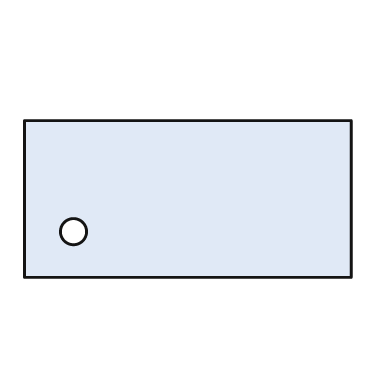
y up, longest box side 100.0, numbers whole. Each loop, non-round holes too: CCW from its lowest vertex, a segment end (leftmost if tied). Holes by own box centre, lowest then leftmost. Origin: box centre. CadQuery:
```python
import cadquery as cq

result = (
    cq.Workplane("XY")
    .moveTo(-50.0, -24.0)
    .lineTo(50.0, -24.0)
    .lineTo(50.0, 24.0)
    .lineTo(-50.0, 24.0)
    .close()
    .moveTo(-35.0, -10.0)
    .circle(4.0)
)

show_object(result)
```